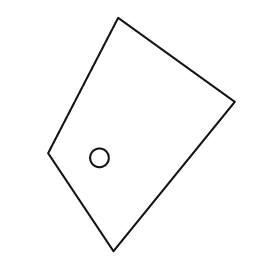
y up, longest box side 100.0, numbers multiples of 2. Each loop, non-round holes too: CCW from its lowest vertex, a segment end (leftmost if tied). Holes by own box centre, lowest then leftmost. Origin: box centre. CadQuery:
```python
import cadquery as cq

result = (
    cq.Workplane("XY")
    .moveTo(-12.0, -50.0)
    .lineTo(40.0, 14.0)
    .lineTo(-10.0, 50.0)
    .lineTo(-40.0, -8.0)
    .close()
    .moveTo(-18.0, -10.0)
    .circle(4.0)
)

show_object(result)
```